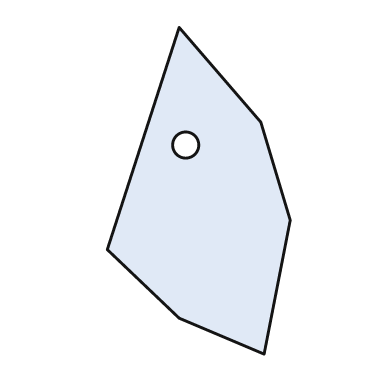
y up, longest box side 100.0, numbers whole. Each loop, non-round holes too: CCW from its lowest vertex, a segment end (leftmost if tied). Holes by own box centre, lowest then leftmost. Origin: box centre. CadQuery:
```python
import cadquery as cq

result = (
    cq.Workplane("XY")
    .moveTo(20.0, -50.0)
    .lineTo(28.0, -9.0)
    .lineTo(19.0, 21.0)
    .lineTo(-6.0, 50.0)
    .lineTo(-28.0, -18.0)
    .lineTo(-6.0, -39.0)
    .close()
    .moveTo(-4.0, 14.0)
    .circle(4.0)
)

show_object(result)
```